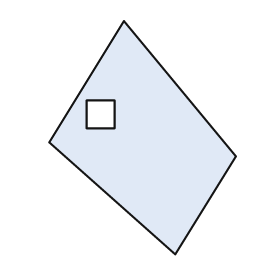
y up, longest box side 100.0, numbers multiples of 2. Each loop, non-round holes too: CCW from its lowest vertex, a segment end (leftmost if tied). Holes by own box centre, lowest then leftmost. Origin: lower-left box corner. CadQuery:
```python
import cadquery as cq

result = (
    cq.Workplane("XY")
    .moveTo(54.0, 0.0)
    .lineTo(80.0, 42.0)
    .lineTo(32.0, 100.0)
    .lineTo(0.0, 48.0)
    .close()
    .moveTo(16.0, 54.0)
    .lineTo(28.0, 54.0)
    .lineTo(28.0, 66.0)
    .lineTo(16.0, 66.0)
    .close()
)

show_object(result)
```